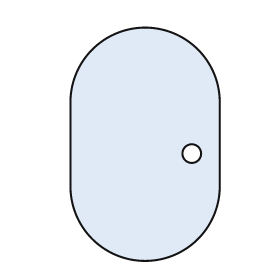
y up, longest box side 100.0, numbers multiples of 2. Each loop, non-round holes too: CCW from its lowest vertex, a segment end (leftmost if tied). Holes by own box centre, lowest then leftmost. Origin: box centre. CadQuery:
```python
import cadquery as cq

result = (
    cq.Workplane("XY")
    .moveTo(-32.0, -18.0)
    .threePointArc((0.0, -50.0), (32.0, -18.0))
    .lineTo(32.0, 18.0)
    .threePointArc((0.0, 50.0), (-32.0, 18.0))
    .close()
    .moveTo(20.0, -4.0)
    .circle(4.0)
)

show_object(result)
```